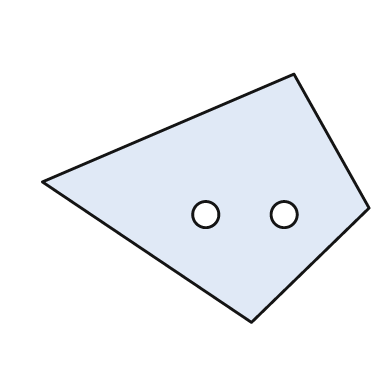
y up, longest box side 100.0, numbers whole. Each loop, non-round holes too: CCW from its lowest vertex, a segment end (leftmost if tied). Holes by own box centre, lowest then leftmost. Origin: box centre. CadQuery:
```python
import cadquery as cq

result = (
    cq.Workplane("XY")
    .moveTo(14.0, -38.0)
    .lineTo(50.0, -3.0)
    .lineTo(27.0, 38.0)
    .lineTo(-50.0, 5.0)
    .close()
    .moveTo(0.0, -5.0)
    .circle(4.0)
    .moveTo(24.0, -5.0)
    .circle(4.0)
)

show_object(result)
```